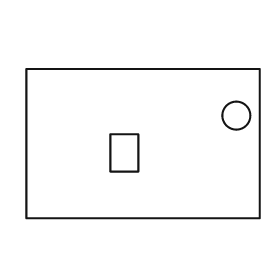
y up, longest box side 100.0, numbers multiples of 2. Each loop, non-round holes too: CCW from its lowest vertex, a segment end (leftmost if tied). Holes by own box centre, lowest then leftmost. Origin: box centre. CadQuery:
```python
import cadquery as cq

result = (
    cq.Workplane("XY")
    .moveTo(-50.0, -32.0)
    .lineTo(50.0, -32.0)
    .lineTo(50.0, 32.0)
    .lineTo(-50.0, 32.0)
    .close()
    .moveTo(-14.0, -12.0)
    .lineTo(-2.0, -12.0)
    .lineTo(-2.0, 4.0)
    .lineTo(-14.0, 4.0)
    .close()
    .moveTo(40.0, 12.0)
    .circle(6.0)
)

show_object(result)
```